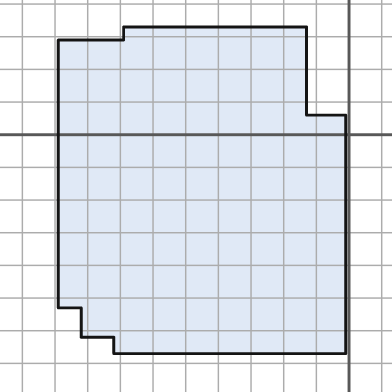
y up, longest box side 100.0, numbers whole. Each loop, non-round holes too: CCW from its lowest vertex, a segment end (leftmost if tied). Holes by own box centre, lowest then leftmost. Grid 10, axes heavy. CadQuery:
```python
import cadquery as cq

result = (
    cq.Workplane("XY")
    .moveTo(-72.0, -67.0)
    .lineTo(-1.0, -67.0)
    .lineTo(-1.0, 6.0)
    .lineTo(-13.0, 6.0)
    .lineTo(-13.0, 33.0)
    .lineTo(-69.0, 33.0)
    .lineTo(-69.0, 29.0)
    .lineTo(-89.0, 29.0)
    .lineTo(-89.0, -53.0)
    .lineTo(-82.0, -53.0)
    .lineTo(-82.0, -62.0)
    .lineTo(-72.0, -62.0)
    .close()
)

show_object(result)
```